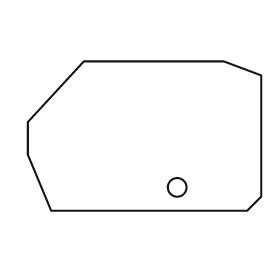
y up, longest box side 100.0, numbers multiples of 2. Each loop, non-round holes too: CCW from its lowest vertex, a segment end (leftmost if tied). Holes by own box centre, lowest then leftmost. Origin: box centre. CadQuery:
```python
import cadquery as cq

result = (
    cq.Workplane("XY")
    .moveTo(-40.0, -32.0)
    .lineTo(44.0, -32.0)
    .lineTo(50.0, -26.0)
    .lineTo(50.0, 26.0)
    .lineTo(34.0, 32.0)
    .lineTo(-26.0, 32.0)
    .lineTo(-50.0, 6.0)
    .lineTo(-50.0, -8.0)
    .close()
    .moveTo(14.0, -22.0)
    .circle(4.0)
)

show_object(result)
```